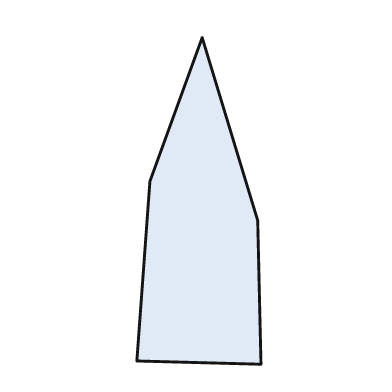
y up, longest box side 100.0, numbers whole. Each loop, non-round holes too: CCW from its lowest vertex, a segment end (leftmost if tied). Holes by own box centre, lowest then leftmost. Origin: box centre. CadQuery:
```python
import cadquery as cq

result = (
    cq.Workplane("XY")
    .moveTo(19.0, -50.0)
    .lineTo(18.0, -6.0)
    .lineTo(1.0, 50.0)
    .lineTo(-15.0, 6.0)
    .lineTo(-19.0, -49.0)
    .close()
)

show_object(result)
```